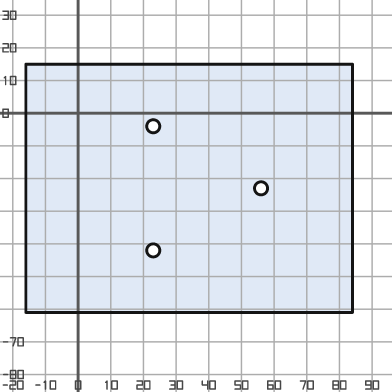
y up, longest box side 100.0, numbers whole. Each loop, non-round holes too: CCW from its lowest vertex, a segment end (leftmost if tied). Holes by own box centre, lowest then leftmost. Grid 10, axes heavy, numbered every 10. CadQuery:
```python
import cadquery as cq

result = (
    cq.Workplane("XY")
    .moveTo(-16.0, -61.0)
    .lineTo(84.0, -61.0)
    .lineTo(84.0, 15.0)
    .lineTo(-16.0, 15.0)
    .close()
    .moveTo(23.0, -42.0)
    .circle(2.0)
    .moveTo(56.0, -23.0)
    .circle(2.0)
    .moveTo(23.0, -4.0)
    .circle(2.0)
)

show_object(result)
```